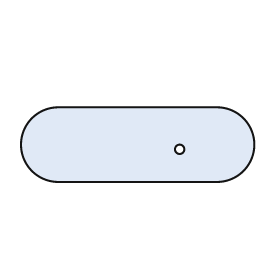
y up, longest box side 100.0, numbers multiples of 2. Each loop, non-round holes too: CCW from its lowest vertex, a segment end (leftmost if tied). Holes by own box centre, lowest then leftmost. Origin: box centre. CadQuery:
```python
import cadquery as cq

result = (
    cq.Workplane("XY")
    .moveTo(-34.0, -16.0)
    .lineTo(34.0, -16.0)
    .threePointArc((50.0, 0.0), (34.0, 16.0))
    .lineTo(-34.0, 16.0)
    .threePointArc((-50.0, 0.0), (-34.0, -16.0))
    .close()
    .moveTo(18.0, -2.0)
    .circle(2.0)
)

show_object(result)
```